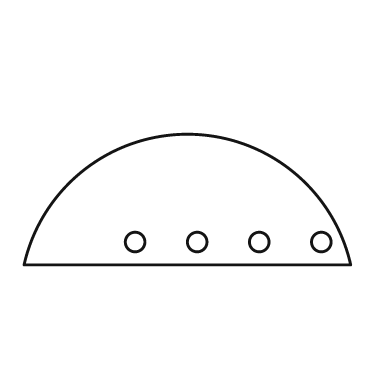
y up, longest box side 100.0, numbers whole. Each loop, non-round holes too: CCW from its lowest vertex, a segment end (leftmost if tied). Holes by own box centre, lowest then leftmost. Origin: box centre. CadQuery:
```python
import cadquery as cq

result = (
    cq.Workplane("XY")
    .moveTo(-50.0, -20.0)
    .lineTo(50.0, -20.0)
    .threePointArc((0.0, 20.0), (-50.0, -20.0))
    .close()
    .moveTo(-16.0, -13.0)
    .circle(3.0)
    .moveTo(3.0, -13.0)
    .circle(3.0)
    .moveTo(22.0, -13.0)
    .circle(3.0)
    .moveTo(41.0, -13.0)
    .circle(3.0)
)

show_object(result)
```